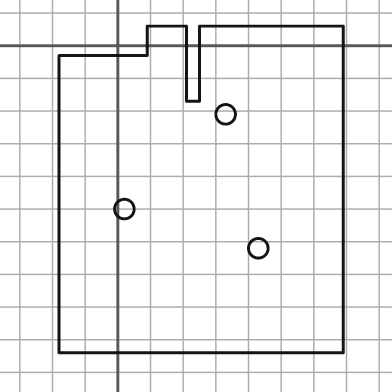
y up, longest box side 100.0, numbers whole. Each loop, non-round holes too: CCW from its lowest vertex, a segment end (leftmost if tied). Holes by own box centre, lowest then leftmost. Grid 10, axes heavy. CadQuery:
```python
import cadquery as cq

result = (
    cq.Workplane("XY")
    .moveTo(-18.0, -94.0)
    .lineTo(69.0, -94.0)
    .lineTo(69.0, 6.0)
    .lineTo(25.0, 6.0)
    .lineTo(25.0, -17.0)
    .lineTo(21.0, -17.0)
    .lineTo(21.0, 6.0)
    .lineTo(9.0, 6.0)
    .lineTo(9.0, -3.0)
    .lineTo(-18.0, -3.0)
    .close()
    .moveTo(43.0, -62.0)
    .circle(3.0)
    .moveTo(2.0, -50.0)
    .circle(3.0)
    .moveTo(33.0, -21.0)
    .circle(3.0)
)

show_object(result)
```